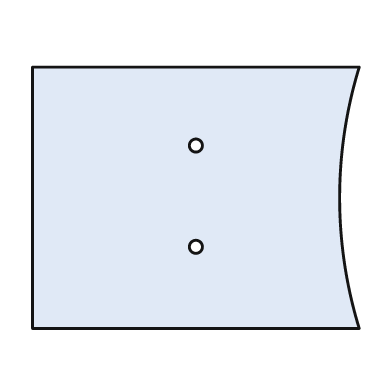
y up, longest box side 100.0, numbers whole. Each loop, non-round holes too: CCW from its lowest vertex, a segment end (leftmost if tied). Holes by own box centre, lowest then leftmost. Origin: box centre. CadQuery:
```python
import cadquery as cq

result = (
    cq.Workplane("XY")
    .moveTo(-50.0, -40.0)
    .lineTo(50.0, -40.0)
    .threePointArc((44.0, 0.0), (50.0, 40.0))
    .lineTo(-50.0, 40.0)
    .close()
    .moveTo(0.0, -15.0)
    .circle(2.0)
    .moveTo(0.0, 16.0)
    .circle(2.0)
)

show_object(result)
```